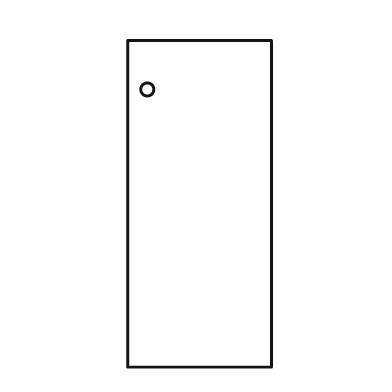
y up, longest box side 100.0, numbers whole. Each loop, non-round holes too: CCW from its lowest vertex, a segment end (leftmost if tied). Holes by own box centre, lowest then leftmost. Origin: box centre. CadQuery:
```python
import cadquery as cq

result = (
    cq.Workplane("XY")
    .moveTo(-22.0, -50.0)
    .lineTo(22.0, -50.0)
    .lineTo(22.0, 50.0)
    .lineTo(-22.0, 50.0)
    .close()
    .moveTo(-16.0, 35.0)
    .circle(2.0)
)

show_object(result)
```